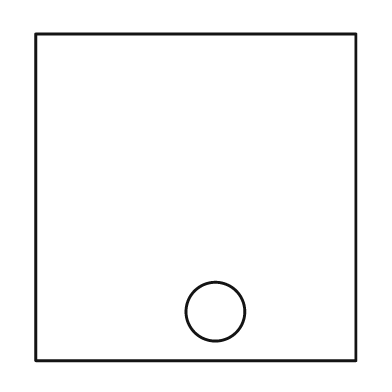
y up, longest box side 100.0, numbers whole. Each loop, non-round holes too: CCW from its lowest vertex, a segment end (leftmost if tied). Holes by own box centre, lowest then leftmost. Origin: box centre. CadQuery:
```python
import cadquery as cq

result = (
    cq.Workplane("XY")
    .moveTo(-49.0, -50.0)
    .lineTo(49.0, -50.0)
    .lineTo(49.0, 50.0)
    .lineTo(-49.0, 50.0)
    .close()
    .moveTo(6.0, -35.0)
    .circle(9.0)
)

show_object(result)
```